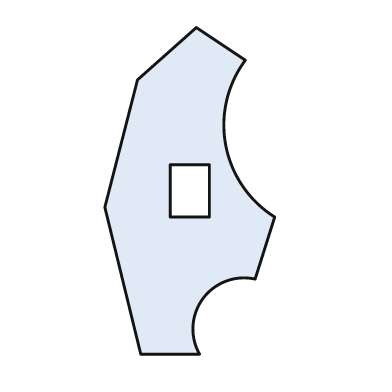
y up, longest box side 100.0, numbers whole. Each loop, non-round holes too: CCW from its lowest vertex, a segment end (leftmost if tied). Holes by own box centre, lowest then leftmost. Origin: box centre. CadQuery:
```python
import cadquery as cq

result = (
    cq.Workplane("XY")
    .moveTo(-15.0, -50.0)
    .lineTo(3.0, -50.0)
    .threePointArc((4.0, -33.0), (20.0, -27.0))
    .lineTo(26.0, -8.0)
    .threePointArc((11.0, 14.0), (17.0, 40.0))
    .lineTo(2.0, 50.0)
    .lineTo(-16.0, 34.0)
    .lineTo(-26.0, -5.0)
    .close()
    .moveTo(-6.0, -8.0)
    .lineTo(6.0, -8.0)
    .lineTo(6.0, 8.0)
    .lineTo(-6.0, 8.0)
    .close()
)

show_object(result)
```